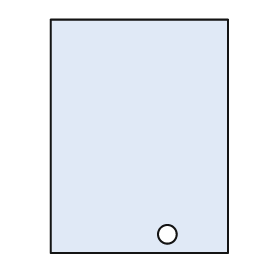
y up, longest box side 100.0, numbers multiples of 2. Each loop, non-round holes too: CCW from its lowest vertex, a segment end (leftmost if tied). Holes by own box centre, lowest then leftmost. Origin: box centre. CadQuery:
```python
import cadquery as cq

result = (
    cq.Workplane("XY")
    .moveTo(-38.0, -50.0)
    .lineTo(38.0, -50.0)
    .lineTo(38.0, 50.0)
    .lineTo(-38.0, 50.0)
    .close()
    .moveTo(12.0, -42.0)
    .circle(4.0)
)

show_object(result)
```